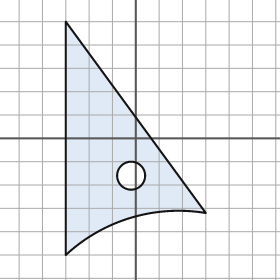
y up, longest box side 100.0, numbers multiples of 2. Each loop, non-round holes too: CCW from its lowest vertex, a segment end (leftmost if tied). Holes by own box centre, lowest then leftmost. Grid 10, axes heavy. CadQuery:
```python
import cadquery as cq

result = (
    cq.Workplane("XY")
    .moveTo(-30.0, -50.0)
    .threePointArc((-2.0, -34.0), (30.0, -32.0))
    .lineTo(-30.0, 50.0)
    .close()
    .moveTo(-2.0, -16.0)
    .circle(6.0)
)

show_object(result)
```